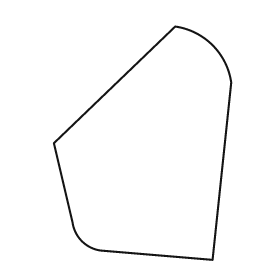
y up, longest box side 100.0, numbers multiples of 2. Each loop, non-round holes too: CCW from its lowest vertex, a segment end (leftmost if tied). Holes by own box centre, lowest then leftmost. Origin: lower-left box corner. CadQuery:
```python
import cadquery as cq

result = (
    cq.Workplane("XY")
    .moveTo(68.0, 0.0)
    .lineTo(76.0, 76.0)
    .threePointArc((68.0, 92.0), (52.0, 100.0))
    .lineTo(0.0, 50.0)
    .lineTo(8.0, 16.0)
    .threePointArc((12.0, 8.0), (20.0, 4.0))
    .close()
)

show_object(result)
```